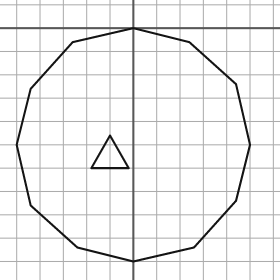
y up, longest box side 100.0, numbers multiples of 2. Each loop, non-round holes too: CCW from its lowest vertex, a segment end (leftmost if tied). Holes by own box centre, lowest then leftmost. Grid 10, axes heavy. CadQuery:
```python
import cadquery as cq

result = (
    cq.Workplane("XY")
    .moveTo(0.0, -100.0)
    .lineTo(26.0, -94.0)
    .lineTo(44.0, -74.0)
    .lineTo(50.0, -50.0)
    .lineTo(44.0, -24.0)
    .lineTo(24.0, -6.0)
    .lineTo(0.0, 0.0)
    .lineTo(-26.0, -6.0)
    .lineTo(-44.0, -26.0)
    .lineTo(-50.0, -50.0)
    .lineTo(-44.0, -76.0)
    .lineTo(-24.0, -94.0)
    .close()
    .moveTo(-18.0, -60.0)
    .lineTo(-2.0, -60.0)
    .lineTo(-10.0, -46.0)
    .close()
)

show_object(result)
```